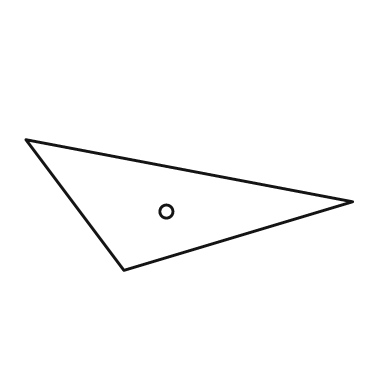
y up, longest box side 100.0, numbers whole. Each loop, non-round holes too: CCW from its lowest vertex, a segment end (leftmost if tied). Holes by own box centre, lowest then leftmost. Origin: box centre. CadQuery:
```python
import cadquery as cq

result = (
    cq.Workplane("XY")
    .moveTo(-20.0, -20.0)
    .lineTo(50.0, 1.0)
    .lineTo(-50.0, 20.0)
    .close()
    .moveTo(-7.0, -2.0)
    .circle(2.0)
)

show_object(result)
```